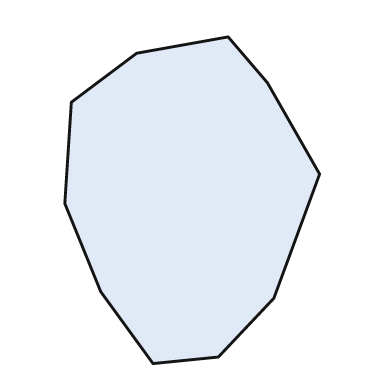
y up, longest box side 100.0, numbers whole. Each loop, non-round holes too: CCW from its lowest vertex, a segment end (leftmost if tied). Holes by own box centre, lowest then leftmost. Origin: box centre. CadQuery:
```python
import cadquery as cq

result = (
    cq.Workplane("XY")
    .moveTo(-12.0, -50.0)
    .lineTo(8.0, -48.0)
    .lineTo(25.0, -30.0)
    .lineTo(39.0, 8.0)
    .lineTo(23.0, 36.0)
    .lineTo(11.0, 50.0)
    .lineTo(-17.0, 45.0)
    .lineTo(-37.0, 30.0)
    .lineTo(-39.0, -1.0)
    .lineTo(-28.0, -28.0)
    .close()
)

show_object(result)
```